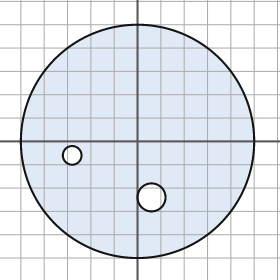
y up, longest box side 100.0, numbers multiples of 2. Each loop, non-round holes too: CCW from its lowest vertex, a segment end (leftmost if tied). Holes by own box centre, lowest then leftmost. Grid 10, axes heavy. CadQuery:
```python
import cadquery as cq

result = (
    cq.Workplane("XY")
    .moveTo(0.0, 0.0)
    .circle(50.0)
    .moveTo(6.0, -24.0)
    .circle(6.0)
    .moveTo(-28.0, -6.0)
    .circle(4.0)
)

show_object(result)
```